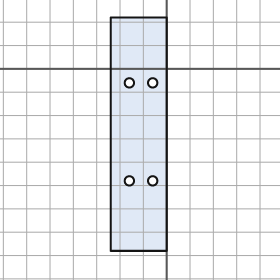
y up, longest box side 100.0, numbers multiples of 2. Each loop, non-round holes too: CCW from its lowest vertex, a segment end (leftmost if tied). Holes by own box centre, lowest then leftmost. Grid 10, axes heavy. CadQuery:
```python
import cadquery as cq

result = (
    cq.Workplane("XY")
    .moveTo(-24.0, -78.0)
    .lineTo(0.0, -78.0)
    .lineTo(0.0, 22.0)
    .lineTo(-24.0, 22.0)
    .close()
    .moveTo(-16.0, -48.0)
    .circle(2.0)
    .moveTo(-6.0, -48.0)
    .circle(2.0)
    .moveTo(-16.0, -6.0)
    .circle(2.0)
    .moveTo(-6.0, -6.0)
    .circle(2.0)
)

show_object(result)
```